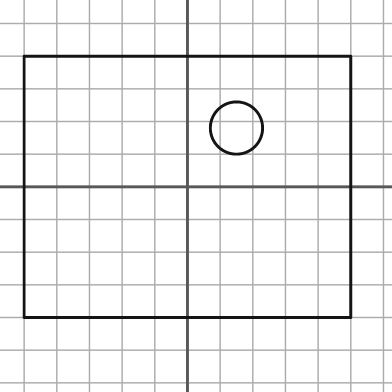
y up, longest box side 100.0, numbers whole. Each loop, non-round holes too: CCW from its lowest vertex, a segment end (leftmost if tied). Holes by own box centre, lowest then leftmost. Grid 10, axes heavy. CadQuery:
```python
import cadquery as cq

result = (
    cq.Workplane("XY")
    .moveTo(-50.0, -40.0)
    .lineTo(50.0, -40.0)
    .lineTo(50.0, 40.0)
    .lineTo(-50.0, 40.0)
    .close()
    .moveTo(15.0, 18.0)
    .circle(8.0)
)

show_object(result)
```